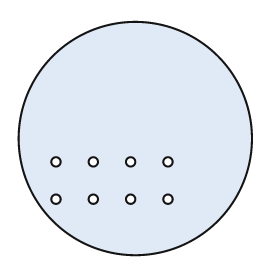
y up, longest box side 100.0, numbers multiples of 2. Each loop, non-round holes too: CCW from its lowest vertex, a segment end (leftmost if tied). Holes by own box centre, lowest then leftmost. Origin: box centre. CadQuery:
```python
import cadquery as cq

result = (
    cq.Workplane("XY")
    .moveTo(0.0, 0.0)
    .circle(50.0)
    .moveTo(-34.0, -26.0)
    .circle(2.0)
    .moveTo(-18.0, -26.0)
    .circle(2.0)
    .moveTo(-2.0, -26.0)
    .circle(2.0)
    .moveTo(14.0, -26.0)
    .circle(2.0)
    .moveTo(-34.0, -10.0)
    .circle(2.0)
    .moveTo(-18.0, -10.0)
    .circle(2.0)
    .moveTo(-2.0, -10.0)
    .circle(2.0)
    .moveTo(14.0, -10.0)
    .circle(2.0)
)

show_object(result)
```